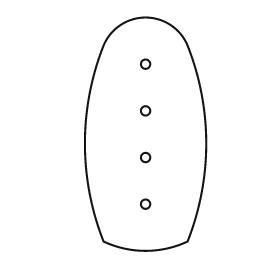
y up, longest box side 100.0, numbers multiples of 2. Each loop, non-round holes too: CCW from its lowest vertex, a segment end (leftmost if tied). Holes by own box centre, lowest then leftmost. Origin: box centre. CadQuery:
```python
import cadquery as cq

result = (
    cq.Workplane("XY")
    .moveTo(-18.0, -46.0)
    .threePointArc((0.0, -50.0), (18.0, -46.0))
    .threePointArc((26.0, -4.0), (18.0, 38.0))
    .threePointArc((0.0, 50.0), (-18.0, 38.0))
    .threePointArc((-26.0, -4.0), (-18.0, -46.0))
    .close()
    .moveTo(0.0, -30.0)
    .circle(2.0)
    .moveTo(0.0, -10.0)
    .circle(2.0)
    .moveTo(0.0, 10.0)
    .circle(2.0)
    .moveTo(0.0, 30.0)
    .circle(2.0)
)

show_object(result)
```